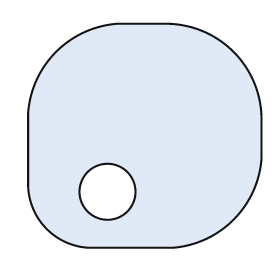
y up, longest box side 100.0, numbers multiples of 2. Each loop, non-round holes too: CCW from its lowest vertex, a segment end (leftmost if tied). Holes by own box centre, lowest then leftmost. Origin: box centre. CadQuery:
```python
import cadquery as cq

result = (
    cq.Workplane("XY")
    .moveTo(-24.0, -48.0)
    .lineTo(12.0, -48.0)
    .threePointArc((38.0, -36.0), (50.0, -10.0))
    .lineTo(50.0, 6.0)
    .threePointArc((38.0, 36.0), (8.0, 48.0))
    .lineTo(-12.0, 48.0)
    .threePointArc((-38.0, 36.0), (-50.0, 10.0))
    .lineTo(-50.0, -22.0)
    .threePointArc((-42.0, -40.0), (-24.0, -48.0))
    .close()
    .moveTo(-16.0, -24.0)
    .circle(12.0)
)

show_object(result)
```